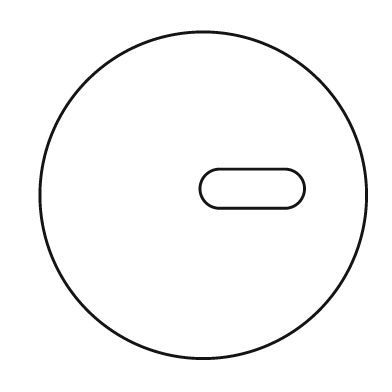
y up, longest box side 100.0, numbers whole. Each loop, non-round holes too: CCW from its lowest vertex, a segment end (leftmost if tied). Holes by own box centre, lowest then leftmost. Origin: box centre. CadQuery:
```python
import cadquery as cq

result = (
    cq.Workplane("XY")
    .moveTo(0.0, 0.0)
    .circle(50.0)
    .moveTo(5.0, -4.0)
    .lineTo(25.0, -4.0)
    .threePointArc((31.0, 2.0), (25.0, 8.0))
    .lineTo(5.0, 8.0)
    .threePointArc((-1.0, 2.0), (5.0, -4.0))
    .close()
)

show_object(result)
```